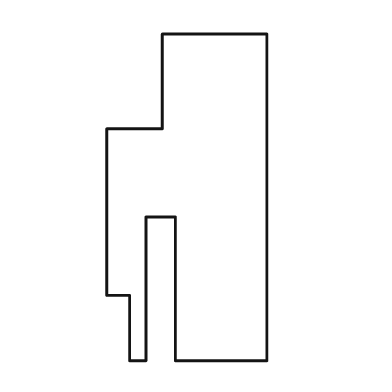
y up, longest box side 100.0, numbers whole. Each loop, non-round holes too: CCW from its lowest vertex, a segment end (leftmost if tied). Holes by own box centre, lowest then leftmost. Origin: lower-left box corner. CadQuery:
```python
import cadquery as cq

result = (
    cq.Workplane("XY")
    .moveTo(7.0, 0.0)
    .lineTo(12.0, 0.0)
    .lineTo(12.0, 44.0)
    .lineTo(21.0, 44.0)
    .lineTo(21.0, 0.0)
    .lineTo(49.0, 0.0)
    .lineTo(49.0, 100.0)
    .lineTo(17.0, 100.0)
    .lineTo(17.0, 71.0)
    .lineTo(0.0, 71.0)
    .lineTo(0.0, 20.0)
    .lineTo(7.0, 20.0)
    .close()
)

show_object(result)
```